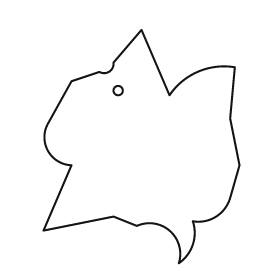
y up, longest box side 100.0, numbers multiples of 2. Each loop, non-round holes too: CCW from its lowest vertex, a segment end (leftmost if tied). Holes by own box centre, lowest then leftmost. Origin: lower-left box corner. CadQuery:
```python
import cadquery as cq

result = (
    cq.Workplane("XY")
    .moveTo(58.0, 0.0)
    .threePointArc((64.0, 8.0), (64.0, 18.0))
    .threePointArc((74.0, 20.0), (80.0, 28.0))
    .lineTo(84.0, 42.0)
    .lineTo(80.0, 62.0)
    .lineTo(82.0, 84.0)
    .threePointArc((66.0, 82.0), (54.0, 72.0))
    .lineTo(42.0, 100.0)
    .lineTo(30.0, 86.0)
    .threePointArc((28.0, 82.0), (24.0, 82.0))
    .lineTo(12.0, 78.0)
    .lineTo(2.0, 60.0)
    .threePointArc((2.0, 48.0), (12.0, 42.0))
    .lineTo(0.0, 14.0)
    .lineTo(30.0, 20.0)
    .lineTo(40.0, 16.0)
    .threePointArc((54.0, 14.0), (58.0, 0.0))
    .close()
    .moveTo(32.0, 74.0)
    .circle(2.0)
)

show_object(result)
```